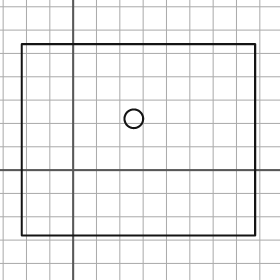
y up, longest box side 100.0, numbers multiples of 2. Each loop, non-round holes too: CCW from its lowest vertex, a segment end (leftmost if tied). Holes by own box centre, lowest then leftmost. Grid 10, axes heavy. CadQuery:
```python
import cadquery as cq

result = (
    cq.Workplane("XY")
    .moveTo(-22.0, -28.0)
    .lineTo(78.0, -28.0)
    .lineTo(78.0, 54.0)
    .lineTo(-22.0, 54.0)
    .close()
    .moveTo(26.0, 22.0)
    .circle(4.0)
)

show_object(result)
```